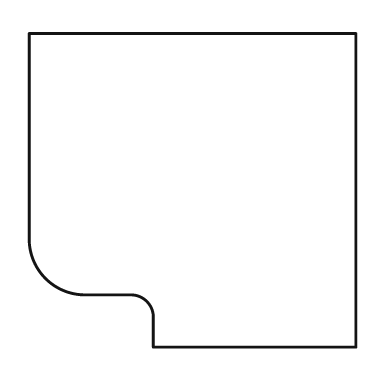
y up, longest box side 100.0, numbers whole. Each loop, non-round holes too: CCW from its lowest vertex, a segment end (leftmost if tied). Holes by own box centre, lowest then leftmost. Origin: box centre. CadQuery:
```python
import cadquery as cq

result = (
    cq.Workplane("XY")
    .moveTo(-12.0, -48.0)
    .lineTo(50.0, -48.0)
    .lineTo(50.0, 48.0)
    .lineTo(-50.0, 48.0)
    .lineTo(-50.0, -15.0)
    .threePointArc((-45.0, -27.0), (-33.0, -32.0))
    .lineTo(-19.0, -32.0)
    .threePointArc((-14.0, -34.0), (-12.0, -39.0))
    .close()
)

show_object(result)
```